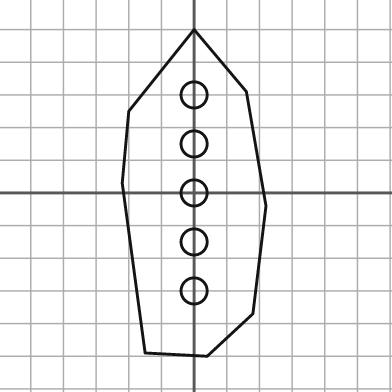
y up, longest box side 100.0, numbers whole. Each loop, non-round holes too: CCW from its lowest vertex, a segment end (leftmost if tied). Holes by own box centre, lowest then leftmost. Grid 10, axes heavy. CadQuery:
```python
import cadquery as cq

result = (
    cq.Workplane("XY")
    .moveTo(4.0, -50.0)
    .lineTo(18.0, -37.0)
    .lineTo(22.0, -4.0)
    .lineTo(16.0, 31.0)
    .lineTo(0.0, 50.0)
    .lineTo(-20.0, 25.0)
    .lineTo(-22.0, 3.0)
    .lineTo(-15.0, -49.0)
    .close()
    .moveTo(0.0, -30.0)
    .circle(4.0)
    .moveTo(0.0, -15.0)
    .circle(4.0)
    .moveTo(0.0, 0.0)
    .circle(4.0)
    .moveTo(0.0, 15.0)
    .circle(4.0)
    .moveTo(0.0, 30.0)
    .circle(4.0)
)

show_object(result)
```